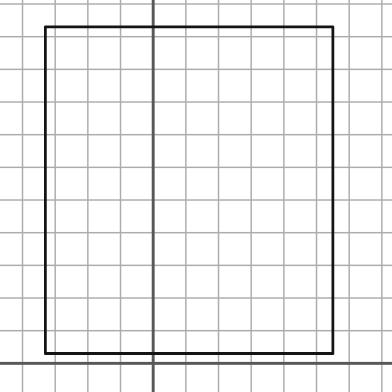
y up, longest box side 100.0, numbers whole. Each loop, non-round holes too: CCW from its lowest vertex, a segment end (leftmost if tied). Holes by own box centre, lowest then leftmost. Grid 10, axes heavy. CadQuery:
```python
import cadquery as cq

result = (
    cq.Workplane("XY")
    .moveTo(-33.0, 3.0)
    .lineTo(55.0, 3.0)
    .lineTo(55.0, 103.0)
    .lineTo(-33.0, 103.0)
    .close()
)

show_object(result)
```